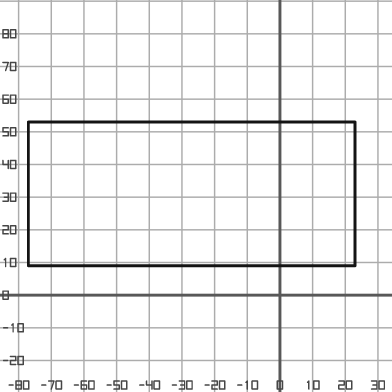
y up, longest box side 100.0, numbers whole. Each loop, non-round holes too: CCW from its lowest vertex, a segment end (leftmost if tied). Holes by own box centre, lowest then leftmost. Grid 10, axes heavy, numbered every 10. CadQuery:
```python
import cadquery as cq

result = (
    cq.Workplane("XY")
    .moveTo(-77.0, 9.0)
    .lineTo(23.0, 9.0)
    .lineTo(23.0, 53.0)
    .lineTo(-77.0, 53.0)
    .close()
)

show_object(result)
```